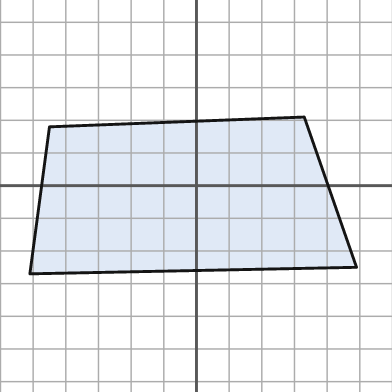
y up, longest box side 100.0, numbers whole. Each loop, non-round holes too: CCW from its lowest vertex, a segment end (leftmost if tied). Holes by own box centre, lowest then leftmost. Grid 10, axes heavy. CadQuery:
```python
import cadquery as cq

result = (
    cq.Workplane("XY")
    .moveTo(-51.0, -27.0)
    .lineTo(49.0, -25.0)
    .lineTo(33.0, 21.0)
    .lineTo(-45.0, 18.0)
    .close()
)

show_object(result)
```